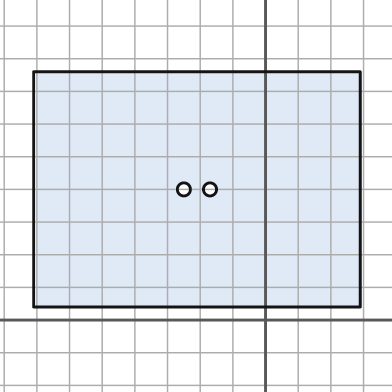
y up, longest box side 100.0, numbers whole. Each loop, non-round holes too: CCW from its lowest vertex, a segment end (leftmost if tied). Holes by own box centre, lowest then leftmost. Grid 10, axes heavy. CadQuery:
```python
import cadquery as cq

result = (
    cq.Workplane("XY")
    .moveTo(-71.0, 4.0)
    .lineTo(29.0, 4.0)
    .lineTo(29.0, 76.0)
    .lineTo(-71.0, 76.0)
    .close()
    .moveTo(-25.0, 40.0)
    .circle(2.0)
    .moveTo(-17.0, 40.0)
    .circle(2.0)
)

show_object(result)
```